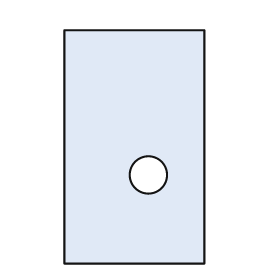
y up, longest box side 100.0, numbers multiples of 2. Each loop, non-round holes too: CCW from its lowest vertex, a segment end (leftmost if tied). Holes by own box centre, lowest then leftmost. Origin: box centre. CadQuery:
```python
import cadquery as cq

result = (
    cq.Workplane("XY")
    .moveTo(-30.0, -50.0)
    .lineTo(30.0, -50.0)
    .lineTo(30.0, 50.0)
    .lineTo(-30.0, 50.0)
    .close()
    .moveTo(6.0, -12.0)
    .circle(8.0)
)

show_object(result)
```